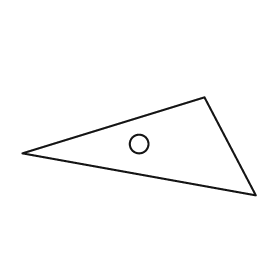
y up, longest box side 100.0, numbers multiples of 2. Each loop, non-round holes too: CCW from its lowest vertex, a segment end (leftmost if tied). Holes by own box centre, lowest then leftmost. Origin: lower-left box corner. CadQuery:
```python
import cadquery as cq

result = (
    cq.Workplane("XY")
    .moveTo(100.0, 0.0)
    .lineTo(78.0, 42.0)
    .lineTo(0.0, 18.0)
    .close()
    .moveTo(50.0, 22.0)
    .circle(4.0)
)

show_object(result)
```